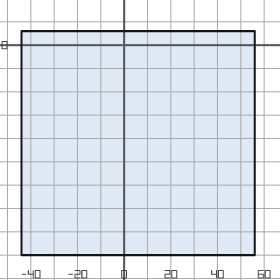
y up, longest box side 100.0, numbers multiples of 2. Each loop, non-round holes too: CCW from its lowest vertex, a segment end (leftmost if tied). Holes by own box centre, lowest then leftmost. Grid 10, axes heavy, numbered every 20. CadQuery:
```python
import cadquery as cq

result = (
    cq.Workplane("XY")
    .moveTo(-44.0, -90.0)
    .lineTo(56.0, -90.0)
    .lineTo(56.0, 6.0)
    .lineTo(-44.0, 6.0)
    .close()
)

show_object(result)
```